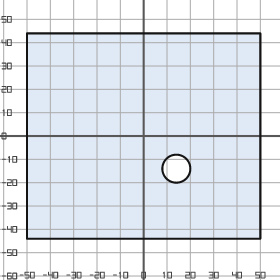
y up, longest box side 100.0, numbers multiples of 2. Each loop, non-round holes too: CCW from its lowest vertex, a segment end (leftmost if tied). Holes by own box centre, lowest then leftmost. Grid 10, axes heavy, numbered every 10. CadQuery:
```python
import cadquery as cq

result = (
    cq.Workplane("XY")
    .moveTo(-50.0, -44.0)
    .lineTo(50.0, -44.0)
    .lineTo(50.0, 44.0)
    .lineTo(-50.0, 44.0)
    .close()
    .moveTo(14.0, -14.0)
    .circle(6.0)
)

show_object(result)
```